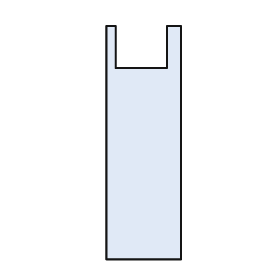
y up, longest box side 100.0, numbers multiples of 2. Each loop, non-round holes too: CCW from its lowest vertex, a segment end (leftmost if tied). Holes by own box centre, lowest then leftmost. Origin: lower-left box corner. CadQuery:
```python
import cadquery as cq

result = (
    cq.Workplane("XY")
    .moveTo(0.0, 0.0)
    .lineTo(32.0, 0.0)
    .lineTo(32.0, 100.0)
    .lineTo(26.0, 100.0)
    .lineTo(26.0, 82.0)
    .lineTo(4.0, 82.0)
    .lineTo(4.0, 100.0)
    .lineTo(0.0, 100.0)
    .close()
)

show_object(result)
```